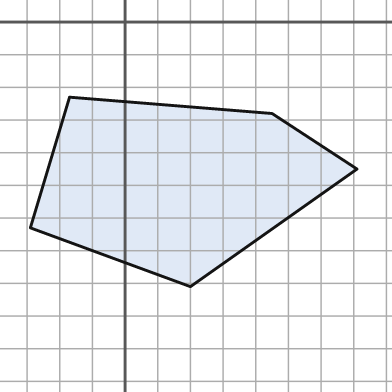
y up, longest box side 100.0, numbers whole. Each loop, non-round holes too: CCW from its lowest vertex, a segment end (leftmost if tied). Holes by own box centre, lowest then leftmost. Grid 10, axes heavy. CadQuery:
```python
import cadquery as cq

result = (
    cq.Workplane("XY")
    .moveTo(20.0, -81.0)
    .lineTo(71.0, -45.0)
    .lineTo(45.0, -28.0)
    .lineTo(-17.0, -23.0)
    .lineTo(-29.0, -63.0)
    .close()
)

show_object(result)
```